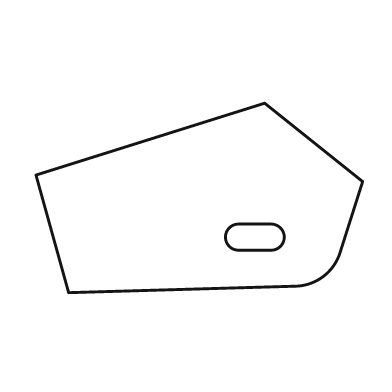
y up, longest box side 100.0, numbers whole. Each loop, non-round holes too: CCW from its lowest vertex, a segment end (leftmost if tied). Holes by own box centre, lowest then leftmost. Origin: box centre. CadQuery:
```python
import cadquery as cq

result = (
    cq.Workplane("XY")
    .moveTo(-40.0, -29.0)
    .lineTo(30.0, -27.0)
    .threePointArc((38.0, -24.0), (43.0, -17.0))
    .lineTo(50.0, 5.0)
    .lineTo(20.0, 29.0)
    .lineTo(-50.0, 7.0)
    .close()
    .moveTo(12.0, -16.0)
    .lineTo(22.0, -16.0)
    .threePointArc((26.0, -12.0), (22.0, -8.0))
    .lineTo(12.0, -8.0)
    .threePointArc((8.0, -12.0), (12.0, -16.0))
    .close()
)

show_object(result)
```